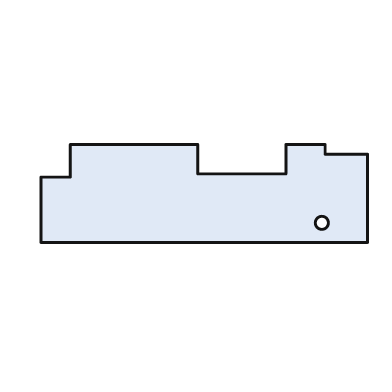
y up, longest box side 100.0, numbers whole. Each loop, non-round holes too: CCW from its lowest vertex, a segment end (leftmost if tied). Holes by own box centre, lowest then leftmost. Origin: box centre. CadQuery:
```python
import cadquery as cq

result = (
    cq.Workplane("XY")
    .moveTo(-50.0, -15.0)
    .lineTo(50.0, -15.0)
    .lineTo(50.0, 12.0)
    .lineTo(37.0, 12.0)
    .lineTo(37.0, 15.0)
    .lineTo(25.0, 15.0)
    .lineTo(25.0, 6.0)
    .lineTo(-2.0, 6.0)
    .lineTo(-2.0, 15.0)
    .lineTo(-41.0, 15.0)
    .lineTo(-41.0, 5.0)
    .lineTo(-50.0, 5.0)
    .close()
    .moveTo(36.0, -9.0)
    .circle(2.0)
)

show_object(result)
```